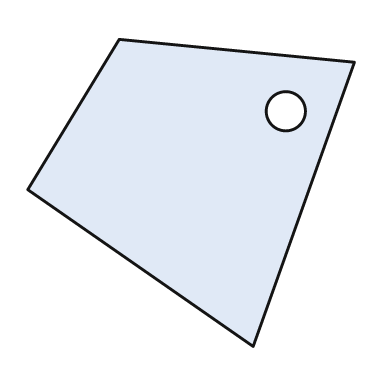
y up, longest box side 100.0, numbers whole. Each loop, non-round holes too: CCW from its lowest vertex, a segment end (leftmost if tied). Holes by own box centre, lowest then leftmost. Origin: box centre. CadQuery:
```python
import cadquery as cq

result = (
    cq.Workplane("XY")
    .moveTo(19.0, -47.0)
    .lineTo(50.0, 40.0)
    .lineTo(-22.0, 47.0)
    .lineTo(-50.0, 1.0)
    .close()
    .moveTo(29.0, 25.0)
    .circle(6.0)
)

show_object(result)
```